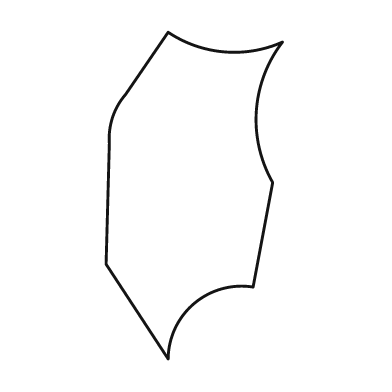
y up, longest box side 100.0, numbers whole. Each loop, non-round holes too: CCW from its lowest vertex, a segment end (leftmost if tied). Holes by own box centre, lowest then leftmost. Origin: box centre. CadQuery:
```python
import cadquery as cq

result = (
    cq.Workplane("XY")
    .moveTo(-8.0, -50.0)
    .threePointArc((0.0, -33.0), (18.0, -28.0))
    .lineTo(24.0, 4.0)
    .threePointArc((19.0, 26.0), (27.0, 47.0))
    .threePointArc((9.0, 44.0), (-8.0, 50.0))
    .lineTo(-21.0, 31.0)
    .threePointArc((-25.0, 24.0), (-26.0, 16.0))
    .lineTo(-27.0, -21.0)
    .close()
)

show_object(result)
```